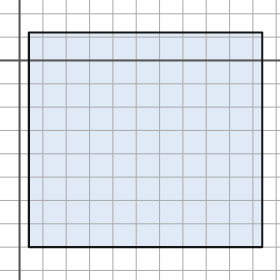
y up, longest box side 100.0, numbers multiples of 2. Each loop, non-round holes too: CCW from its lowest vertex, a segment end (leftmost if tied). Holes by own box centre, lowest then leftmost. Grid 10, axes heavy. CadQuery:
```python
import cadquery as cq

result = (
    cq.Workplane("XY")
    .moveTo(4.0, -80.0)
    .lineTo(104.0, -80.0)
    .lineTo(104.0, 12.0)
    .lineTo(4.0, 12.0)
    .close()
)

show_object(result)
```